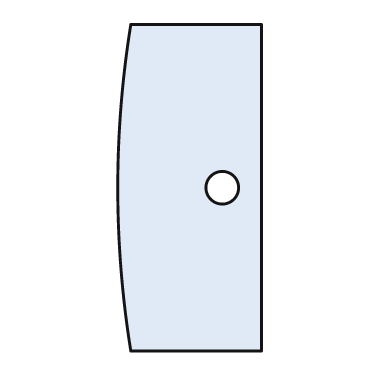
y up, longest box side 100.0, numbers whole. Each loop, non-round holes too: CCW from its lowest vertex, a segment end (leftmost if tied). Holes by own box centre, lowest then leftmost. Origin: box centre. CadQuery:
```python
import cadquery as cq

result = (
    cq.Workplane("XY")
    .moveTo(-18.0, -50.0)
    .lineTo(22.0, -50.0)
    .lineTo(22.0, 50.0)
    .lineTo(-18.0, 50.0)
    .threePointArc((-22.0, 0.0), (-18.0, -50.0))
    .close()
    .moveTo(10.0, 0.0)
    .circle(5.0)
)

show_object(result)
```